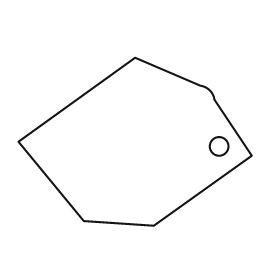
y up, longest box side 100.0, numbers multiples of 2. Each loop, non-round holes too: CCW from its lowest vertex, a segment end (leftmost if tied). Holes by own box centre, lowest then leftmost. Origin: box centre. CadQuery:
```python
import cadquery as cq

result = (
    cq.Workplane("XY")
    .moveTo(8.0, -36.0)
    .lineTo(50.0, -6.0)
    .lineTo(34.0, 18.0)
    .threePointArc((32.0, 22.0), (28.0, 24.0))
    .lineTo(0.0, 36.0)
    .lineTo(-50.0, 0.0)
    .lineTo(-22.0, -34.0)
    .close()
    .moveTo(36.0, -2.0)
    .circle(4.0)
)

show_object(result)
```